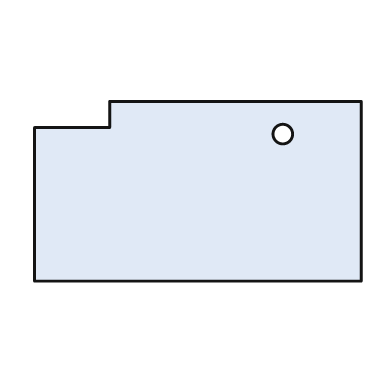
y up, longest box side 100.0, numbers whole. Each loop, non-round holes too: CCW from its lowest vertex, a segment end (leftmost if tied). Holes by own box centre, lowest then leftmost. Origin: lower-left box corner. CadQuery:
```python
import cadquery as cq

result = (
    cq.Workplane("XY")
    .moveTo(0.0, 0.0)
    .lineTo(100.0, 0.0)
    .lineTo(100.0, 55.0)
    .lineTo(23.0, 55.0)
    .lineTo(23.0, 47.0)
    .lineTo(0.0, 47.0)
    .close()
    .moveTo(76.0, 45.0)
    .circle(3.0)
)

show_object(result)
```